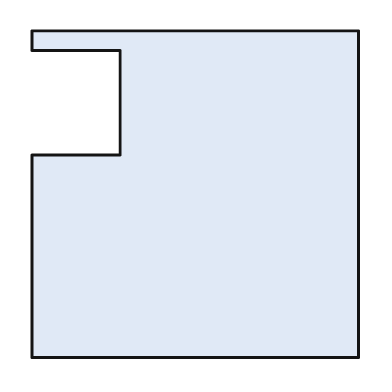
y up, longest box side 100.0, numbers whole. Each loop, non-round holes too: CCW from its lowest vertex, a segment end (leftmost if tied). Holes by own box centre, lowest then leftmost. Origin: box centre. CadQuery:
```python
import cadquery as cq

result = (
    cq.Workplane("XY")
    .moveTo(-50.0, -50.0)
    .lineTo(50.0, -50.0)
    .lineTo(50.0, 50.0)
    .lineTo(-50.0, 50.0)
    .lineTo(-50.0, 44.0)
    .lineTo(-23.0, 44.0)
    .lineTo(-23.0, 12.0)
    .lineTo(-50.0, 12.0)
    .close()
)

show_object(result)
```